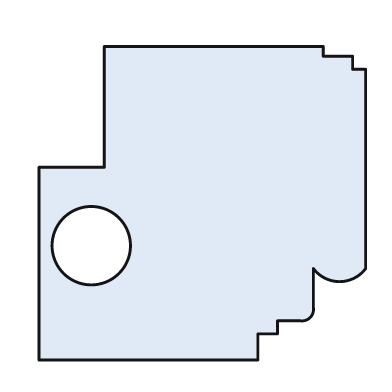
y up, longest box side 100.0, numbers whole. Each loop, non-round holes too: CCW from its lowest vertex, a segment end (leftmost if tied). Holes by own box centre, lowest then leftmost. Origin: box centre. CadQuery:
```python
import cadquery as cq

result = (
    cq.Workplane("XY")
    .moveTo(-50.0, -48.0)
    .lineTo(17.0, -48.0)
    .lineTo(17.0, -40.0)
    .lineTo(23.0, -40.0)
    .lineTo(23.0, -36.0)
    .lineTo(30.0, -36.0)
    .threePointArc((33.0, -35.0), (34.0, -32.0))
    .lineTo(34.0, -20.0)
    .threePointArc((42.0, -24.0), (50.0, -20.0))
    .lineTo(50.0, 41.0)
    .lineTo(46.0, 41.0)
    .lineTo(46.0, 45.0)
    .lineTo(37.0, 45.0)
    .lineTo(37.0, 48.0)
    .lineTo(-30.0, 48.0)
    .lineTo(-30.0, 11.0)
    .lineTo(-50.0, 11.0)
    .close()
    .moveTo(-34.0, -13.0)
    .circle(12.0)
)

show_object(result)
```